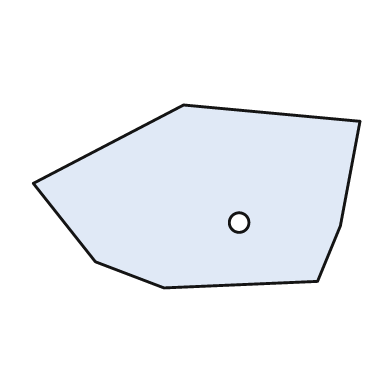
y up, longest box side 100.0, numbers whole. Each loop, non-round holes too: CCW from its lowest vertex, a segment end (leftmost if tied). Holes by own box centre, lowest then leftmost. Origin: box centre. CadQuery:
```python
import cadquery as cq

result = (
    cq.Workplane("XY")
    .moveTo(-10.0, -28.0)
    .lineTo(37.0, -26.0)
    .lineTo(44.0, -9.0)
    .lineTo(50.0, 23.0)
    .lineTo(-4.0, 28.0)
    .lineTo(-50.0, 4.0)
    .lineTo(-31.0, -20.0)
    .close()
    .moveTo(13.0, -8.0)
    .circle(3.0)
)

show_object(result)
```